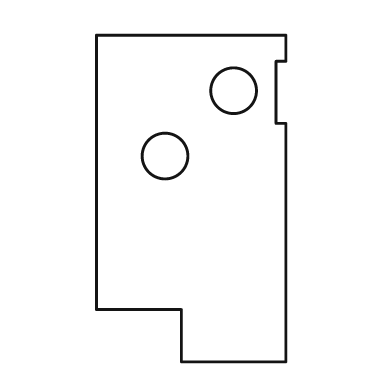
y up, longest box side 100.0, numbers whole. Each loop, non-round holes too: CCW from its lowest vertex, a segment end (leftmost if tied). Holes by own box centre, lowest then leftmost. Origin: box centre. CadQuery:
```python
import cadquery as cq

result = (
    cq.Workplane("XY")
    .moveTo(-3.0, -50.0)
    .lineTo(29.0, -50.0)
    .lineTo(29.0, 23.0)
    .lineTo(26.0, 23.0)
    .lineTo(26.0, 42.0)
    .lineTo(29.0, 42.0)
    .lineTo(29.0, 50.0)
    .lineTo(-29.0, 50.0)
    .lineTo(-29.0, -34.0)
    .lineTo(-3.0, -34.0)
    .close()
    .moveTo(-8.0, 13.0)
    .circle(7.0)
    .moveTo(13.0, 33.0)
    .circle(7.0)
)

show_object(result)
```